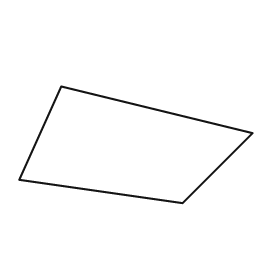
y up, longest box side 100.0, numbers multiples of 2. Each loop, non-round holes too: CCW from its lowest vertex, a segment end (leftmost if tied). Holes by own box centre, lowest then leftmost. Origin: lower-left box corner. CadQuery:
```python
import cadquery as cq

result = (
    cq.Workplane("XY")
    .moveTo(70.0, 0.0)
    .lineTo(100.0, 30.0)
    .lineTo(18.0, 50.0)
    .lineTo(0.0, 10.0)
    .close()
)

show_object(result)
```